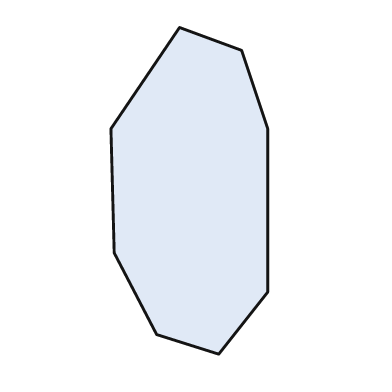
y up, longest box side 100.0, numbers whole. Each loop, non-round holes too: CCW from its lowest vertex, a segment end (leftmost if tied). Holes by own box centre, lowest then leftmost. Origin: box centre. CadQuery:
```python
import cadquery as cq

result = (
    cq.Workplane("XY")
    .moveTo(9.0, -50.0)
    .lineTo(24.0, -31.0)
    .lineTo(24.0, 19.0)
    .lineTo(16.0, 43.0)
    .lineTo(-3.0, 50.0)
    .lineTo(-24.0, 19.0)
    .lineTo(-23.0, -19.0)
    .lineTo(-10.0, -44.0)
    .close()
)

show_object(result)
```